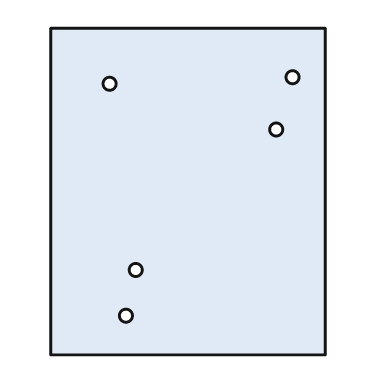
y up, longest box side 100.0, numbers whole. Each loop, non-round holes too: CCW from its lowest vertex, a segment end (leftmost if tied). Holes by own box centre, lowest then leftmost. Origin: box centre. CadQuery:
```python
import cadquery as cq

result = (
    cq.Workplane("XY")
    .moveTo(-42.0, -50.0)
    .lineTo(42.0, -50.0)
    .lineTo(42.0, 50.0)
    .lineTo(-42.0, 50.0)
    .close()
    .moveTo(-19.0, -38.0)
    .circle(2.0)
    .moveTo(-16.0, -24.0)
    .circle(2.0)
    .moveTo(27.0, 19.0)
    .circle(2.0)
    .moveTo(-24.0, 33.0)
    .circle(2.0)
    .moveTo(32.0, 35.0)
    .circle(2.0)
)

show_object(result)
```